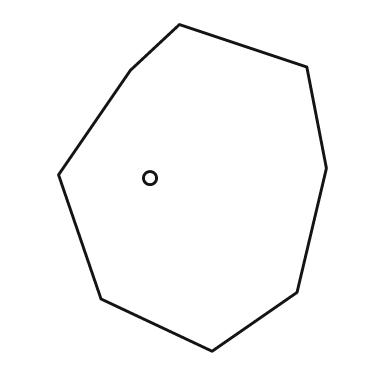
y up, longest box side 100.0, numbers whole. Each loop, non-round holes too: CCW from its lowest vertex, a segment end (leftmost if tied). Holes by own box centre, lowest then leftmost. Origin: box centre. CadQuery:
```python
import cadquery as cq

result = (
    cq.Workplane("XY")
    .moveTo(6.0, -50.0)
    .lineTo(32.0, -32.0)
    .lineTo(41.0, 6.0)
    .lineTo(35.0, 37.0)
    .lineTo(-4.0, 50.0)
    .lineTo(-19.0, 36.0)
    .lineTo(-41.0, 4.0)
    .lineTo(-28.0, -34.0)
    .close()
    .moveTo(-13.0, 3.0)
    .circle(2.0)
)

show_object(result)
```